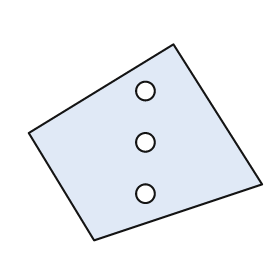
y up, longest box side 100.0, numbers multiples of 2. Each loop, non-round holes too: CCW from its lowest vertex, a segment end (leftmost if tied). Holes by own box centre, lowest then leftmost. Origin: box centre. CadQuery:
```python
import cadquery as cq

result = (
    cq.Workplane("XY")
    .moveTo(-22.0, -42.0)
    .lineTo(50.0, -18.0)
    .lineTo(12.0, 42.0)
    .lineTo(-50.0, 4.0)
    .close()
    .moveTo(0.0, -22.0)
    .circle(4.0)
    .moveTo(0.0, 0.0)
    .circle(4.0)
    .moveTo(0.0, 22.0)
    .circle(4.0)
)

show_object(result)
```